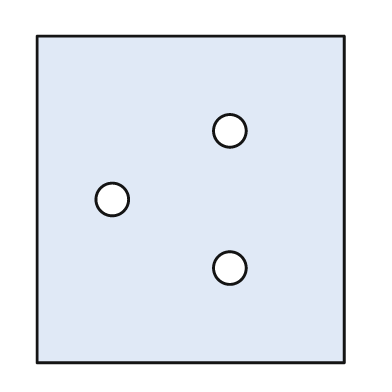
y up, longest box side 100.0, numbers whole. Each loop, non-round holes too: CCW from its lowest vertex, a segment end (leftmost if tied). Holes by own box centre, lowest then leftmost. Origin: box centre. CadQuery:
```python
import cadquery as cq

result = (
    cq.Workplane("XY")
    .moveTo(-47.0, -50.0)
    .lineTo(47.0, -50.0)
    .lineTo(47.0, 50.0)
    .lineTo(-47.0, 50.0)
    .close()
    .moveTo(12.0, -21.0)
    .circle(5.0)
    .moveTo(-24.0, 0.0)
    .circle(5.0)
    .moveTo(12.0, 21.0)
    .circle(5.0)
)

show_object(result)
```